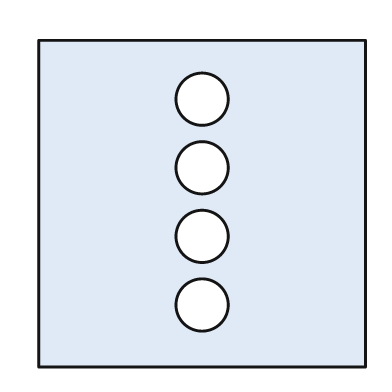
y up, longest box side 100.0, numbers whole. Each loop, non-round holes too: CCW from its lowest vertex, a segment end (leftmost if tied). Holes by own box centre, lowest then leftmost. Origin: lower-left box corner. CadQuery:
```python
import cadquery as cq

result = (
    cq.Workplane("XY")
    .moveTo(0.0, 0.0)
    .lineTo(100.0, 0.0)
    .lineTo(100.0, 100.0)
    .lineTo(0.0, 100.0)
    .close()
    .moveTo(50.0, 19.0)
    .circle(8.0)
    .moveTo(50.0, 40.0)
    .circle(8.0)
    .moveTo(50.0, 61.0)
    .circle(8.0)
    .moveTo(50.0, 82.0)
    .circle(8.0)
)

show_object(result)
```